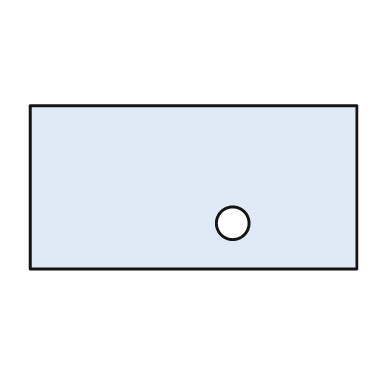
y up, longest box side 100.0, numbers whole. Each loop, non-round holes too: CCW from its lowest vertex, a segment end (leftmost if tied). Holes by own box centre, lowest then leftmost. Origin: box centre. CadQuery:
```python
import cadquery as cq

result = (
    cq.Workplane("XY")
    .moveTo(-50.0, -25.0)
    .lineTo(50.0, -25.0)
    .lineTo(50.0, 25.0)
    .lineTo(-50.0, 25.0)
    .close()
    .moveTo(12.0, -11.0)
    .circle(5.0)
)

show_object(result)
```